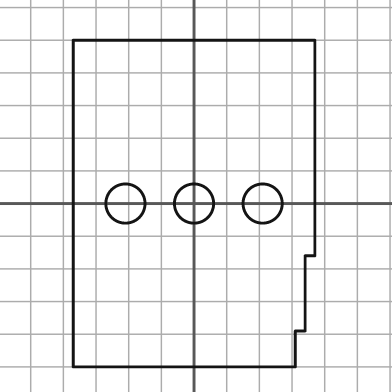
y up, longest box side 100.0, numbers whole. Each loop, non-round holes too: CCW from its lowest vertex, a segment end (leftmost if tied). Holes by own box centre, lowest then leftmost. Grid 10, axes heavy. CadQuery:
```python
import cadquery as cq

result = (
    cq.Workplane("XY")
    .moveTo(-37.0, -50.0)
    .lineTo(31.0, -50.0)
    .lineTo(31.0, -39.0)
    .lineTo(34.0, -39.0)
    .lineTo(34.0, -16.0)
    .lineTo(37.0, -16.0)
    .lineTo(37.0, 50.0)
    .lineTo(-37.0, 50.0)
    .close()
    .moveTo(-21.0, 0.0)
    .circle(6.0)
    .moveTo(0.0, 0.0)
    .circle(6.0)
    .moveTo(21.0, 0.0)
    .circle(6.0)
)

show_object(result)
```